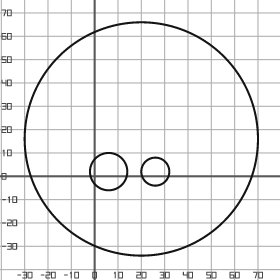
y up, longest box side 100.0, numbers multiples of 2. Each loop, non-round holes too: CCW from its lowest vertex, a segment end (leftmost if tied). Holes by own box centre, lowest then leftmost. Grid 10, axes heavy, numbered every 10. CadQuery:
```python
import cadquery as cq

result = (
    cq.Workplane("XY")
    .moveTo(20.0, 16.0)
    .circle(50.0)
    .moveTo(6.0, 2.0)
    .circle(8.0)
    .moveTo(26.0, 2.0)
    .circle(6.0)
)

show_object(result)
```